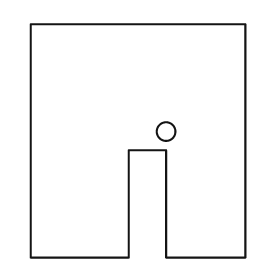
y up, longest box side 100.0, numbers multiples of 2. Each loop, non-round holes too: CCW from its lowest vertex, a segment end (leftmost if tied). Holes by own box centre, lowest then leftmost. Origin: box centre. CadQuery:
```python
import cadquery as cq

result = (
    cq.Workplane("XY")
    .moveTo(-46.0, -50.0)
    .lineTo(-4.0, -50.0)
    .lineTo(-4.0, -4.0)
    .lineTo(12.0, -4.0)
    .lineTo(12.0, -50.0)
    .lineTo(46.0, -50.0)
    .lineTo(46.0, 50.0)
    .lineTo(-46.0, 50.0)
    .close()
    .moveTo(12.0, 4.0)
    .circle(4.0)
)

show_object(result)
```